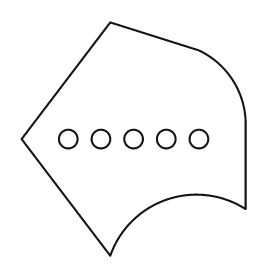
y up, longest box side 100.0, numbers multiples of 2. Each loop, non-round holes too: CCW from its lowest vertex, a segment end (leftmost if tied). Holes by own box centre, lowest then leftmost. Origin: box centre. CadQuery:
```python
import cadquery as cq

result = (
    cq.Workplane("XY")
    .moveTo(-10.0, -50.0)
    .threePointArc((14.0, -26.0), (48.0, -30.0))
    .lineTo(48.0, 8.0)
    .threePointArc((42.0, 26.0), (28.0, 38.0))
    .lineTo(-10.0, 50.0)
    .lineTo(-48.0, 0.0)
    .close()
    .moveTo(-28.0, 0.0)
    .circle(4.0)
    .moveTo(-14.0, 0.0)
    .circle(4.0)
    .moveTo(0.0, 0.0)
    .circle(4.0)
    .moveTo(14.0, 0.0)
    .circle(4.0)
    .moveTo(28.0, 0.0)
    .circle(4.0)
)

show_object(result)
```